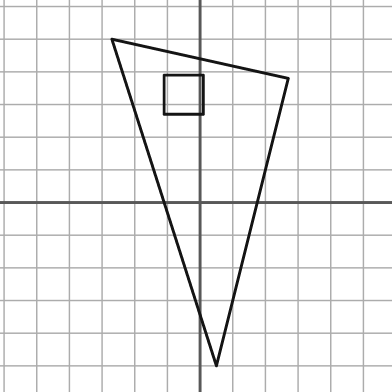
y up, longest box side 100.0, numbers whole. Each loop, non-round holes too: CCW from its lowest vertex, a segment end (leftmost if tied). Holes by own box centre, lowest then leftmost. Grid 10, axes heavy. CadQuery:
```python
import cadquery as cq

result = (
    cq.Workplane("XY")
    .moveTo(5.0, -50.0)
    .lineTo(27.0, 38.0)
    .lineTo(-27.0, 50.0)
    .close()
    .moveTo(-11.0, 27.0)
    .lineTo(1.0, 27.0)
    .lineTo(1.0, 39.0)
    .lineTo(-11.0, 39.0)
    .close()
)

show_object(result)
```